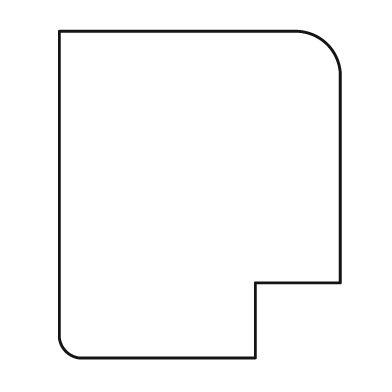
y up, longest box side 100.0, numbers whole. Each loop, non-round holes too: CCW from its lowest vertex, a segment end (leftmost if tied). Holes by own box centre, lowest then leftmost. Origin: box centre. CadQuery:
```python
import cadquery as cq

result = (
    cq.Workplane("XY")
    .moveTo(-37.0, -50.0)
    .lineTo(17.0, -50.0)
    .lineTo(17.0, -27.0)
    .lineTo(43.0, -27.0)
    .lineTo(43.0, 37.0)
    .threePointArc((39.0, 46.0), (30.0, 50.0))
    .lineTo(-43.0, 50.0)
    .lineTo(-43.0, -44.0)
    .threePointArc((-41.0, -48.0), (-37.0, -50.0))
    .close()
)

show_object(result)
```